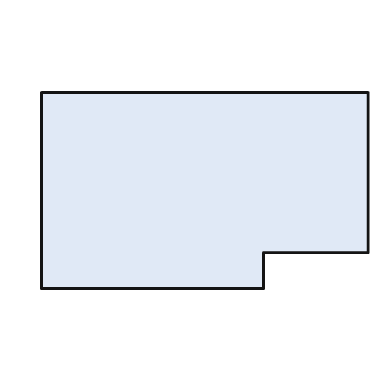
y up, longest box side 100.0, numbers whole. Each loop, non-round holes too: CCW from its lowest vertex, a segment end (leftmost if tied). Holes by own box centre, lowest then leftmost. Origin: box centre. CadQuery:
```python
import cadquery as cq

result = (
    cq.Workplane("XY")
    .moveTo(-50.0, -30.0)
    .lineTo(18.0, -30.0)
    .lineTo(18.0, -19.0)
    .lineTo(50.0, -19.0)
    .lineTo(50.0, 30.0)
    .lineTo(-50.0, 30.0)
    .close()
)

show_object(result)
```